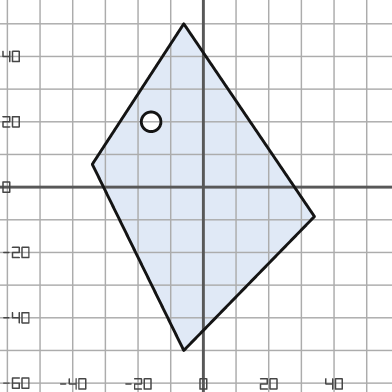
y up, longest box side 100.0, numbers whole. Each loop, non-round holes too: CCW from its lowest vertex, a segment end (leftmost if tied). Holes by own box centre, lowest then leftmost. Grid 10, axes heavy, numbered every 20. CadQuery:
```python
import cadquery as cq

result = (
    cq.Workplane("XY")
    .moveTo(-6.0, -50.0)
    .lineTo(34.0, -9.0)
    .lineTo(-6.0, 50.0)
    .lineTo(-34.0, 7.0)
    .close()
    .moveTo(-16.0, 20.0)
    .circle(3.0)
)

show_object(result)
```